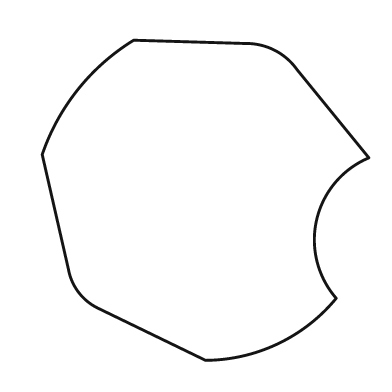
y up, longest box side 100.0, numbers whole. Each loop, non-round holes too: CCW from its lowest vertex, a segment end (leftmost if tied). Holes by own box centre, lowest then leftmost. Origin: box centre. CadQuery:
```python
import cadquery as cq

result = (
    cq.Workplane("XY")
    .moveTo(0.0, -49.0)
    .threePointArc((22.0, -44.0), (40.0, -30.0))
    .threePointArc((34.0, -6.0), (50.0, 13.0))
    .lineTo(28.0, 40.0)
    .threePointArc((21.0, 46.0), (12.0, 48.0))
    .lineTo(-22.0, 49.0)
    .threePointArc((-39.0, 34.0), (-50.0, 14.0))
    .lineTo(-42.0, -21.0)
    .threePointArc((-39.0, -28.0), (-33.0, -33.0))
    .close()
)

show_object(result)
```